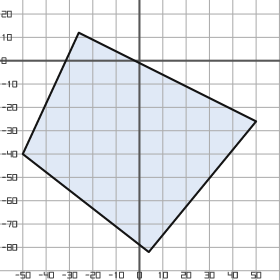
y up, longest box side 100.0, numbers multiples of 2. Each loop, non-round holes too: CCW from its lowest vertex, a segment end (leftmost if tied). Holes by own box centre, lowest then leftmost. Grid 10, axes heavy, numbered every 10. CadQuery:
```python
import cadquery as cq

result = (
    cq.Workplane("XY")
    .moveTo(4.0, -82.0)
    .lineTo(50.0, -26.0)
    .lineTo(-26.0, 12.0)
    .lineTo(-50.0, -40.0)
    .close()
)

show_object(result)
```